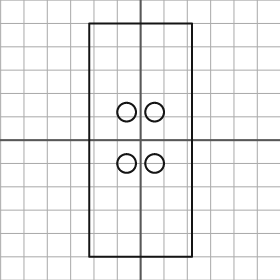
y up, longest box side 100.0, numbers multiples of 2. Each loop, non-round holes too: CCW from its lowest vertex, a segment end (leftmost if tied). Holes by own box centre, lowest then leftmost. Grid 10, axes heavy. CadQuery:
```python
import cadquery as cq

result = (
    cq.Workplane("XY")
    .moveTo(-22.0, -50.0)
    .lineTo(22.0, -50.0)
    .lineTo(22.0, 50.0)
    .lineTo(-22.0, 50.0)
    .close()
    .moveTo(-6.0, -10.0)
    .circle(4.0)
    .moveTo(6.0, -10.0)
    .circle(4.0)
    .moveTo(-6.0, 12.0)
    .circle(4.0)
    .moveTo(6.0, 12.0)
    .circle(4.0)
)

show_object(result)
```